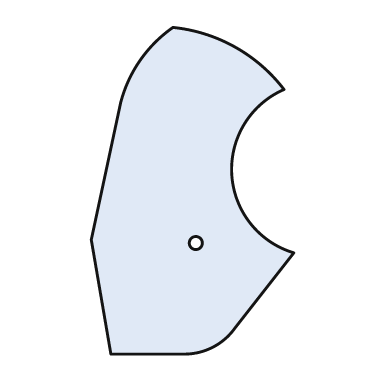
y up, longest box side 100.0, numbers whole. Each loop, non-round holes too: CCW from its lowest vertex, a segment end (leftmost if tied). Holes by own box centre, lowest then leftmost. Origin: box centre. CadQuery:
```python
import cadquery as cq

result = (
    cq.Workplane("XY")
    .moveTo(-25.0, -50.0)
    .lineTo(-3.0, -50.0)
    .threePointArc((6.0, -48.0), (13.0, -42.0))
    .lineTo(31.0, -19.0)
    .threePointArc((12.0, 5.0), (28.0, 31.0))
    .threePointArc((13.0, 44.0), (-6.0, 50.0))
    .threePointArc((-16.0, 40.0), (-22.0, 27.0))
    .lineTo(-31.0, -15.0)
    .close()
    .moveTo(1.0, -16.0)
    .circle(2.0)
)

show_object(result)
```